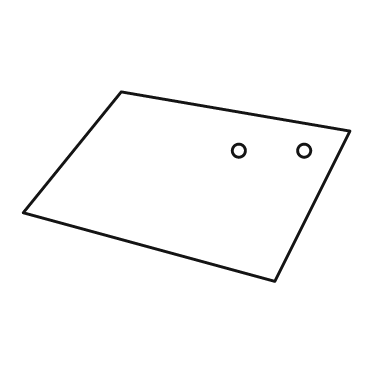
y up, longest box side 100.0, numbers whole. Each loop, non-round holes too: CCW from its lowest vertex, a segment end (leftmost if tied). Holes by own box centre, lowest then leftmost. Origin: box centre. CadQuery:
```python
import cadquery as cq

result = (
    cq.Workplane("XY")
    .moveTo(27.0, -29.0)
    .lineTo(50.0, 17.0)
    .lineTo(-20.0, 29.0)
    .lineTo(-50.0, -8.0)
    .close()
    .moveTo(16.0, 11.0)
    .circle(2.0)
    .moveTo(36.0, 11.0)
    .circle(2.0)
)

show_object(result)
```